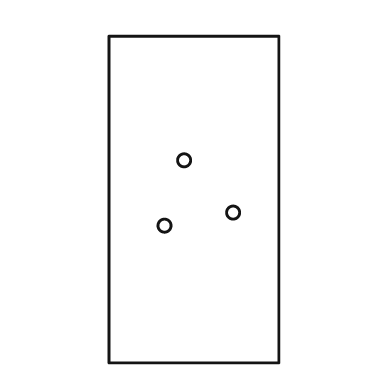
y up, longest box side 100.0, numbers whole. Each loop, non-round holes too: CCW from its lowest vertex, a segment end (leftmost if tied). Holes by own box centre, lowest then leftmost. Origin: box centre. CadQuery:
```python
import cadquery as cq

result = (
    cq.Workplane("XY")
    .moveTo(-26.0, -50.0)
    .lineTo(26.0, -50.0)
    .lineTo(26.0, 50.0)
    .lineTo(-26.0, 50.0)
    .close()
    .moveTo(-9.0, -8.0)
    .circle(2.0)
    .moveTo(12.0, -4.0)
    .circle(2.0)
    .moveTo(-3.0, 12.0)
    .circle(2.0)
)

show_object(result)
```